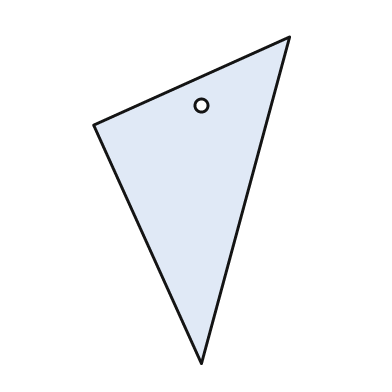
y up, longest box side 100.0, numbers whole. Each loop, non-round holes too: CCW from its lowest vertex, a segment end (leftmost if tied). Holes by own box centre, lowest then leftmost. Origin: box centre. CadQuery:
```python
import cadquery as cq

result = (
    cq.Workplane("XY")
    .moveTo(3.0, -50.0)
    .lineTo(30.0, 50.0)
    .lineTo(-30.0, 23.0)
    .close()
    .moveTo(3.0, 29.0)
    .circle(2.0)
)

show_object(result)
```